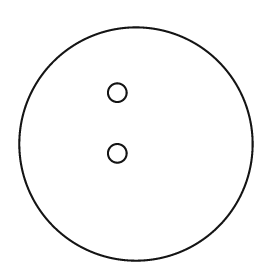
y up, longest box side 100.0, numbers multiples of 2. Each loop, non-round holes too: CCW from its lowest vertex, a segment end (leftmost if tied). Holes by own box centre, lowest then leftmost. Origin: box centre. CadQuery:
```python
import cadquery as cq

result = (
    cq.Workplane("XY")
    .moveTo(0.0, 0.0)
    .circle(50.0)
    .moveTo(-8.0, -4.0)
    .circle(4.0)
    .moveTo(-8.0, 22.0)
    .circle(4.0)
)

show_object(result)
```